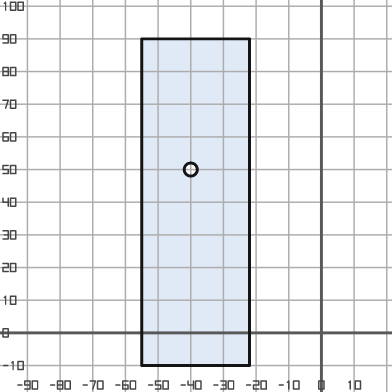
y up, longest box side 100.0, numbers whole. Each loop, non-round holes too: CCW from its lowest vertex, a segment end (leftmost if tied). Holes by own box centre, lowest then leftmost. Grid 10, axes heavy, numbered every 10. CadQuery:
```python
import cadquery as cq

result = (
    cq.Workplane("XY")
    .moveTo(-55.0, -10.0)
    .lineTo(-22.0, -10.0)
    .lineTo(-22.0, 90.0)
    .lineTo(-55.0, 90.0)
    .close()
    .moveTo(-40.0, 50.0)
    .circle(2.0)
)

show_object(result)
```